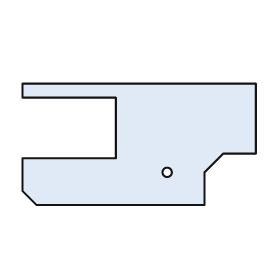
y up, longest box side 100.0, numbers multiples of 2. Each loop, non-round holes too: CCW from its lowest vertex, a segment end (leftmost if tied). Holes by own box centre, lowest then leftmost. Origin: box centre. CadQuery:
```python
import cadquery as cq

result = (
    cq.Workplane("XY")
    .moveTo(-44.0, -26.0)
    .lineTo(28.0, -26.0)
    .lineTo(28.0, -12.0)
    .lineTo(36.0, -4.0)
    .lineTo(50.0, -4.0)
    .lineTo(50.0, 26.0)
    .lineTo(-50.0, 26.0)
    .lineTo(-50.0, 20.0)
    .lineTo(-10.0, 20.0)
    .lineTo(-10.0, -6.0)
    .lineTo(-50.0, -6.0)
    .lineTo(-50.0, -20.0)
    .close()
    .moveTo(12.0, -12.0)
    .circle(2.0)
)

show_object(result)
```